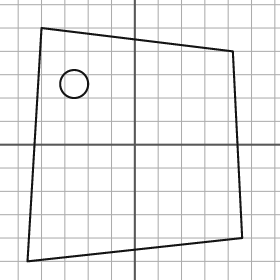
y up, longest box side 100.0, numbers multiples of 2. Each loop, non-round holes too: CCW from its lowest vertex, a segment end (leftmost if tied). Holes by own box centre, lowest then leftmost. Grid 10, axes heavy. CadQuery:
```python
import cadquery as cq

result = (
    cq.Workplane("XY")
    .moveTo(-46.0, -50.0)
    .lineTo(46.0, -40.0)
    .lineTo(42.0, 40.0)
    .lineTo(-40.0, 50.0)
    .close()
    .moveTo(-26.0, 26.0)
    .circle(6.0)
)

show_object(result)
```